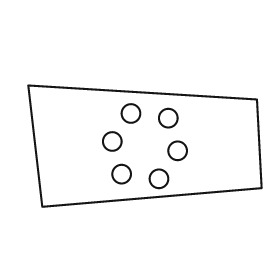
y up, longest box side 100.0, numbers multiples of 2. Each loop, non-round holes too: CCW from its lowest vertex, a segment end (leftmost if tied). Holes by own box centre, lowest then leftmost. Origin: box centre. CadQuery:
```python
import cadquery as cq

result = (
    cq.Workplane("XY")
    .moveTo(-44.0, -26.0)
    .lineTo(50.0, -18.0)
    .lineTo(48.0, 20.0)
    .lineTo(-50.0, 26.0)
    .close()
    .moveTo(6.0, -14.0)
    .circle(4.0)
    .moveTo(-10.0, -12.0)
    .circle(4.0)
    .moveTo(14.0, -2.0)
    .circle(4.0)
    .moveTo(-14.0, 2.0)
    .circle(4.0)
    .moveTo(10.0, 12.0)
    .circle(4.0)
    .moveTo(-6.0, 14.0)
    .circle(4.0)
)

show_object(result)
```